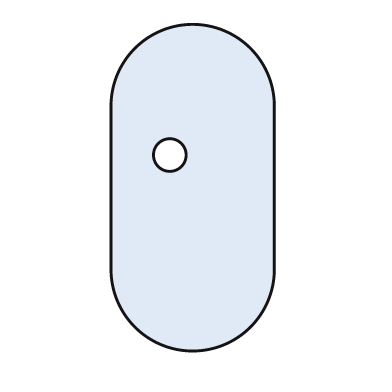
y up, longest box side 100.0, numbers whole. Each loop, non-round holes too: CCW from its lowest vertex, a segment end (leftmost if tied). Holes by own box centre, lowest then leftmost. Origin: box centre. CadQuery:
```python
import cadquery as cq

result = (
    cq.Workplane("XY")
    .moveTo(-25.0, -25.0)
    .threePointArc((0.0, -50.0), (25.0, -25.0))
    .lineTo(25.0, 25.0)
    .threePointArc((0.0, 50.0), (-25.0, 25.0))
    .close()
    .moveTo(-7.0, 10.0)
    .circle(5.0)
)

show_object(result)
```